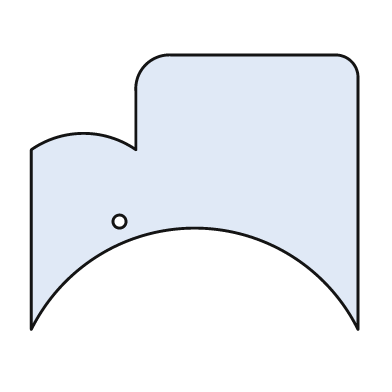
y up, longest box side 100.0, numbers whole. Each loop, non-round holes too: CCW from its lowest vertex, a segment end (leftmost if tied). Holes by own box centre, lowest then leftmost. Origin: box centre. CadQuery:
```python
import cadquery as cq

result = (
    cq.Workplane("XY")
    .moveTo(-50.0, -42.0)
    .threePointArc((0.0, -11.0), (50.0, -42.0))
    .lineTo(50.0, 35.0)
    .threePointArc((48.0, 40.0), (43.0, 42.0))
    .lineTo(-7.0, 42.0)
    .threePointArc((-15.0, 39.0), (-18.0, 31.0))
    .lineTo(-18.0, 13.0)
    .threePointArc((-34.0, 18.0), (-50.0, 13.0))
    .close()
    .moveTo(-23.0, -9.0)
    .circle(2.0)
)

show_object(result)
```